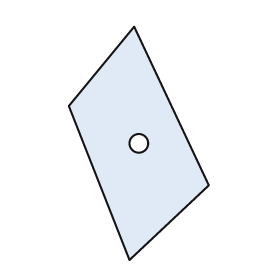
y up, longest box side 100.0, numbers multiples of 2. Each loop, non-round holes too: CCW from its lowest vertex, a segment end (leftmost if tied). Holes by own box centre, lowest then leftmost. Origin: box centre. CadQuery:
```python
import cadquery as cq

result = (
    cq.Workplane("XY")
    .moveTo(-4.0, -50.0)
    .lineTo(30.0, -18.0)
    .lineTo(-2.0, 50.0)
    .lineTo(-30.0, 16.0)
    .close()
    .moveTo(0.0, 0.0)
    .circle(4.0)
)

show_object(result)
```